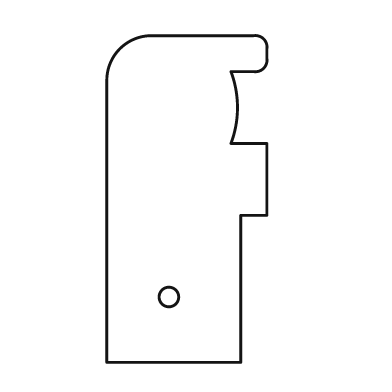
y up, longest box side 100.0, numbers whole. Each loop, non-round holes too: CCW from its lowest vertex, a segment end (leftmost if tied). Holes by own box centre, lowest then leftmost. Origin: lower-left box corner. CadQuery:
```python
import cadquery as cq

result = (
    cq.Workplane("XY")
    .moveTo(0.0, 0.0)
    .lineTo(41.0, 0.0)
    .lineTo(41.0, 45.0)
    .lineTo(49.0, 45.0)
    .lineTo(49.0, 67.0)
    .lineTo(38.0, 67.0)
    .threePointArc((40.0, 78.0), (38.0, 89.0))
    .lineTo(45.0, 89.0)
    .threePointArc((48.0, 90.0), (49.0, 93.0))
    .lineTo(49.0, 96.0)
    .threePointArc((48.0, 99.0), (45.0, 100.0))
    .lineTo(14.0, 100.0)
    .threePointArc((4.0, 96.0), (0.0, 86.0))
    .close()
    .moveTo(19.0, 20.0)
    .circle(3.0)
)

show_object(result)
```